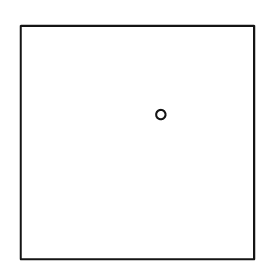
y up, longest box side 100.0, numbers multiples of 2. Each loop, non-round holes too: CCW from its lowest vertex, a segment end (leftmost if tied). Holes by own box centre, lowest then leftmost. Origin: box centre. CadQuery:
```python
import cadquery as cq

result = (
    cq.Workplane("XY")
    .moveTo(-50.0, -50.0)
    .lineTo(50.0, -50.0)
    .lineTo(50.0, 50.0)
    .lineTo(-50.0, 50.0)
    .close()
    .moveTo(10.0, 12.0)
    .circle(2.0)
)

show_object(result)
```